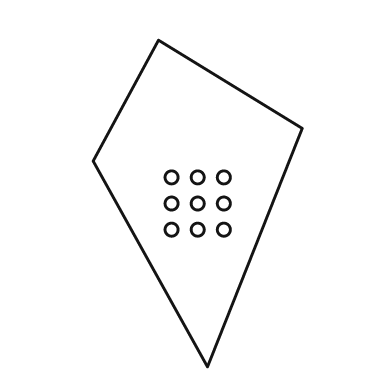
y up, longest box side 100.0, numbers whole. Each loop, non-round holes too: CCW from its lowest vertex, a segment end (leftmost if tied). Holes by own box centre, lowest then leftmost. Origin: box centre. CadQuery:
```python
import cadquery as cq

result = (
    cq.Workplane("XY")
    .moveTo(3.0, -50.0)
    .lineTo(32.0, 23.0)
    .lineTo(-12.0, 50.0)
    .lineTo(-32.0, 13.0)
    .close()
    .moveTo(-8.0, -8.0)
    .circle(2.0)
    .moveTo(0.0, -8.0)
    .circle(2.0)
    .moveTo(8.0, -8.0)
    .circle(2.0)
    .moveTo(-8.0, 0.0)
    .circle(2.0)
    .moveTo(0.0, 0.0)
    .circle(2.0)
    .moveTo(8.0, 0.0)
    .circle(2.0)
    .moveTo(-8.0, 8.0)
    .circle(2.0)
    .moveTo(0.0, 8.0)
    .circle(2.0)
    .moveTo(8.0, 8.0)
    .circle(2.0)
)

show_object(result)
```